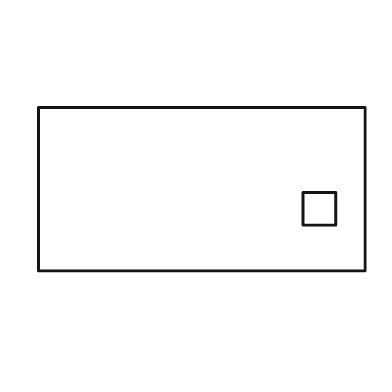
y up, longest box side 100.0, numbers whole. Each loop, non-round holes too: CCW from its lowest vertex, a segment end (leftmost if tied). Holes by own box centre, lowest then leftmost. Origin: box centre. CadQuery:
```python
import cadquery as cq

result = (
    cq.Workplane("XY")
    .moveTo(-50.0, -25.0)
    .lineTo(50.0, -25.0)
    .lineTo(50.0, 25.0)
    .lineTo(-50.0, 25.0)
    .close()
    .moveTo(31.0, -11.0)
    .lineTo(41.0, -11.0)
    .lineTo(41.0, -1.0)
    .lineTo(31.0, -1.0)
    .close()
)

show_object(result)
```